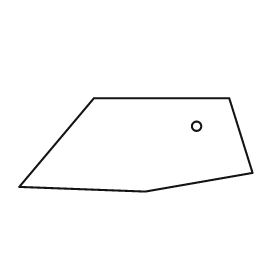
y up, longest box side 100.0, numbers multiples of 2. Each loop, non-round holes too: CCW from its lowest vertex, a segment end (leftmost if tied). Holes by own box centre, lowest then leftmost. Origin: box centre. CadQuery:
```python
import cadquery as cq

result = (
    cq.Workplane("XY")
    .moveTo(4.0, -20.0)
    .lineTo(50.0, -12.0)
    .lineTo(40.0, 20.0)
    .lineTo(-18.0, 20.0)
    .lineTo(-50.0, -18.0)
    .close()
    .moveTo(26.0, 8.0)
    .circle(2.0)
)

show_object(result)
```